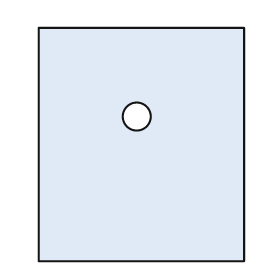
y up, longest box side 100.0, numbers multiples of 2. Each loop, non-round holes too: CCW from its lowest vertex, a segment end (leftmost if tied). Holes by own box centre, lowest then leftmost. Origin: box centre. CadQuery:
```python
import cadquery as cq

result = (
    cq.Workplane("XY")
    .moveTo(-44.0, -50.0)
    .lineTo(44.0, -50.0)
    .lineTo(44.0, 50.0)
    .lineTo(-44.0, 50.0)
    .close()
    .moveTo(-2.0, 12.0)
    .circle(6.0)
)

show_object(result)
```